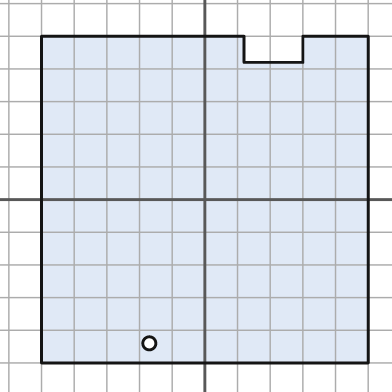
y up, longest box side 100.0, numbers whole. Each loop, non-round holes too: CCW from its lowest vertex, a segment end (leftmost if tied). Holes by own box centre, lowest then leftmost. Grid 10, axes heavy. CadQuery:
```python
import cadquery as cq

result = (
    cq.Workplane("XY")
    .moveTo(-50.0, -50.0)
    .lineTo(50.0, -50.0)
    .lineTo(50.0, 50.0)
    .lineTo(30.0, 50.0)
    .lineTo(30.0, 42.0)
    .lineTo(12.0, 42.0)
    .lineTo(12.0, 50.0)
    .lineTo(-50.0, 50.0)
    .close()
    .moveTo(-17.0, -44.0)
    .circle(2.0)
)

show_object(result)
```